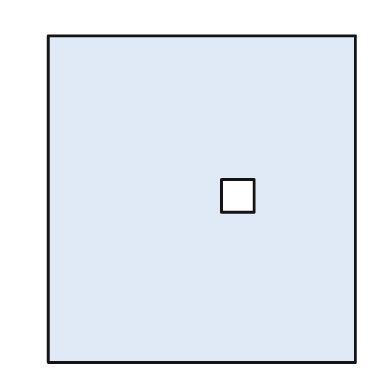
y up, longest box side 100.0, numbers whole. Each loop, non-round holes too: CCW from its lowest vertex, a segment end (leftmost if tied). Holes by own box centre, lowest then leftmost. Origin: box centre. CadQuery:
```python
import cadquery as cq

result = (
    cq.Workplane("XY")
    .moveTo(-47.0, -50.0)
    .lineTo(47.0, -50.0)
    .lineTo(47.0, 50.0)
    .lineTo(-47.0, 50.0)
    .close()
    .moveTo(6.0, -4.0)
    .lineTo(16.0, -4.0)
    .lineTo(16.0, 6.0)
    .lineTo(6.0, 6.0)
    .close()
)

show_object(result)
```